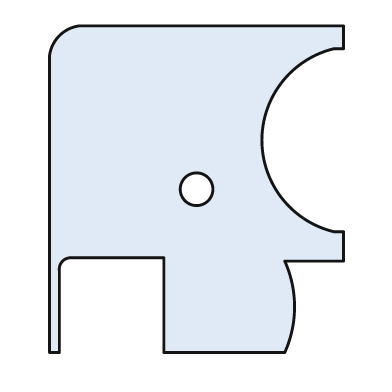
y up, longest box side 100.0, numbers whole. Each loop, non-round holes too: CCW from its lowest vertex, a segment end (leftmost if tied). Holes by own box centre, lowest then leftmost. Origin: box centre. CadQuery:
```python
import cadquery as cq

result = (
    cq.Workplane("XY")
    .moveTo(-45.0, -50.0)
    .lineTo(-42.0, -50.0)
    .lineTo(-42.0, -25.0)
    .threePointArc((-41.0, -22.0), (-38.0, -21.0))
    .lineTo(-10.0, -21.0)
    .lineTo(-10.0, -50.0)
    .lineTo(27.0, -50.0)
    .threePointArc((30.0, -36.0), (27.0, -22.0))
    .lineTo(45.0, -22.0)
    .lineTo(45.0, -13.0)
    .lineTo(42.0, -13.0)
    .threePointArc((20.0, 15.0), (42.0, 43.0))
    .lineTo(45.0, 43.0)
    .lineTo(45.0, 50.0)
    .lineTo(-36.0, 50.0)
    .threePointArc((-42.0, 47.0), (-45.0, 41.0))
    .close()
    .moveTo(0.0, 0.0)
    .circle(5.0)
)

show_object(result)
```